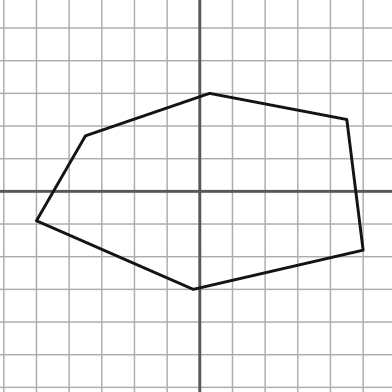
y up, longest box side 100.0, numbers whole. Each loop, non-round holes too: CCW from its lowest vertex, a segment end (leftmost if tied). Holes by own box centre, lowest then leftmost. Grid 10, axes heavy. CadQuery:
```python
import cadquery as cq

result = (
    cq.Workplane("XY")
    .moveTo(-2.0, -30.0)
    .lineTo(50.0, -18.0)
    .lineTo(45.0, 22.0)
    .lineTo(3.0, 30.0)
    .lineTo(-35.0, 17.0)
    .lineTo(-50.0, -9.0)
    .close()
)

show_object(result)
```